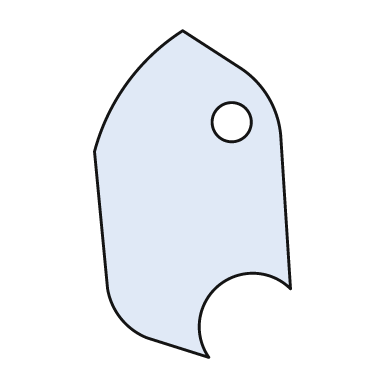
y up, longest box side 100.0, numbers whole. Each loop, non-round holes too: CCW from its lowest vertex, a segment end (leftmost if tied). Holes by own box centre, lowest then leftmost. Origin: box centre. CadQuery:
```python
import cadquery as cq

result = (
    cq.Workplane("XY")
    .moveTo(5.0, -50.0)
    .threePointArc((8.0, -28.0), (30.0, -29.0))
    .lineTo(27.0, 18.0)
    .threePointArc((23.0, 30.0), (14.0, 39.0))
    .lineTo(-3.0, 50.0)
    .threePointArc((-20.0, 34.0), (-30.0, 13.0))
    .lineTo(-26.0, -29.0)
    .threePointArc((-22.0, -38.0), (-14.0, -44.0))
    .close()
    .moveTo(12.0, 22.0)
    .circle(6.0)
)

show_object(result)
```